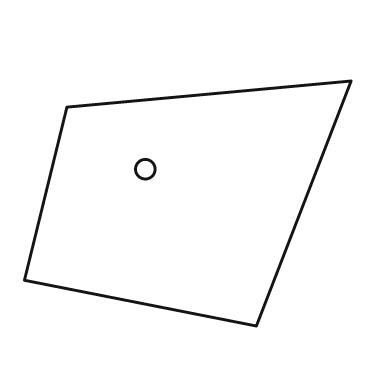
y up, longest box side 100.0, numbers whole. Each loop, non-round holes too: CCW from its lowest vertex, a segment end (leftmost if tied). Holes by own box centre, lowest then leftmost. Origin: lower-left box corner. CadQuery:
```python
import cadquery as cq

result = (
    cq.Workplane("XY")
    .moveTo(71.0, 0.0)
    .lineTo(100.0, 75.0)
    .lineTo(13.0, 67.0)
    .lineTo(0.0, 14.0)
    .close()
    .moveTo(37.0, 48.0)
    .circle(3.0)
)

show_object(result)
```